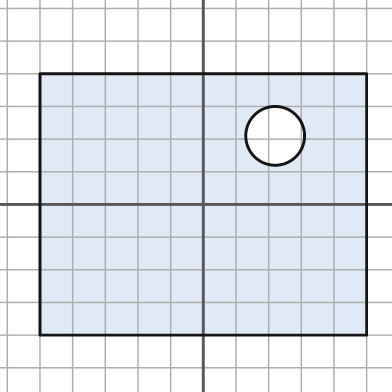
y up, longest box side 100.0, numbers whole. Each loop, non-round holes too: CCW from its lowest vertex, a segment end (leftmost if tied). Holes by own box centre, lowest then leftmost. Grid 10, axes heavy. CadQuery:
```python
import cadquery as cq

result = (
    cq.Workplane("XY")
    .moveTo(-50.0, -40.0)
    .lineTo(50.0, -40.0)
    .lineTo(50.0, 40.0)
    .lineTo(-50.0, 40.0)
    .close()
    .moveTo(22.0, 21.0)
    .circle(9.0)
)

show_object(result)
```